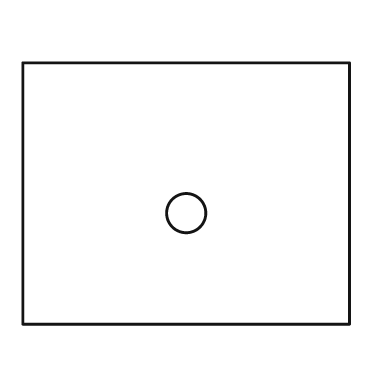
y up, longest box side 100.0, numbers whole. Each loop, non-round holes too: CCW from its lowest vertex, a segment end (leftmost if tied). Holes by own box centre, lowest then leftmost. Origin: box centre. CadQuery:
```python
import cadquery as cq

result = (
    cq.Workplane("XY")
    .moveTo(-50.0, -40.0)
    .lineTo(50.0, -40.0)
    .lineTo(50.0, 40.0)
    .lineTo(-50.0, 40.0)
    .close()
    .moveTo(0.0, -6.0)
    .circle(6.0)
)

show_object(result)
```